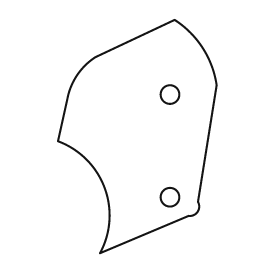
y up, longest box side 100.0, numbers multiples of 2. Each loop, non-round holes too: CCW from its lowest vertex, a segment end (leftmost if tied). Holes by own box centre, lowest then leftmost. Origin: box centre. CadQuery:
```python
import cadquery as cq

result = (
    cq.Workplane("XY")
    .moveTo(-16.0, -50.0)
    .lineTo(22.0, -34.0)
    .threePointArc((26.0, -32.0), (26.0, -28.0))
    .lineTo(34.0, 22.0)
    .threePointArc((28.0, 38.0), (16.0, 50.0))
    .lineTo(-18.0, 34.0)
    .threePointArc((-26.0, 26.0), (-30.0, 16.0))
    .lineTo(-34.0, -2.0)
    .threePointArc((-14.0, -22.0), (-16.0, -50.0))
    .close()
    .moveTo(14.0, -26.0)
    .circle(4.0)
    .moveTo(14.0, 18.0)
    .circle(4.0)
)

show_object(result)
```